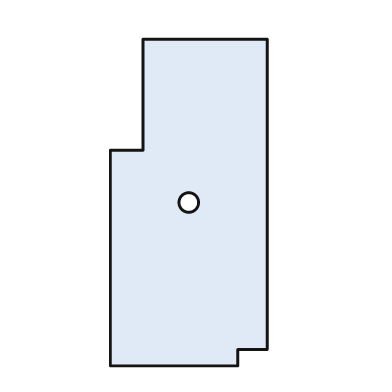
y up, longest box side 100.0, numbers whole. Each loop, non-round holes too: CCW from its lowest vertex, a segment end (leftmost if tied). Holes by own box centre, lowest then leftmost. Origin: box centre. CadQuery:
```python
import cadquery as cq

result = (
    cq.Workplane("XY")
    .moveTo(-24.0, -50.0)
    .lineTo(15.0, -50.0)
    .lineTo(15.0, -45.0)
    .lineTo(24.0, -45.0)
    .lineTo(24.0, 50.0)
    .lineTo(-14.0, 50.0)
    .lineTo(-14.0, 16.0)
    .lineTo(-24.0, 16.0)
    .close()
    .moveTo(0.0, 0.0)
    .circle(3.0)
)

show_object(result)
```